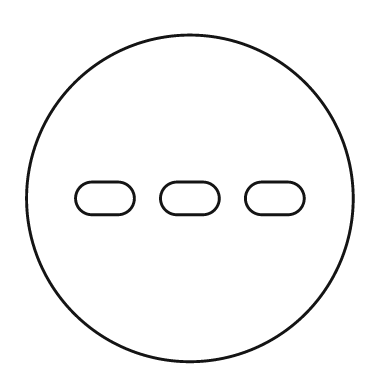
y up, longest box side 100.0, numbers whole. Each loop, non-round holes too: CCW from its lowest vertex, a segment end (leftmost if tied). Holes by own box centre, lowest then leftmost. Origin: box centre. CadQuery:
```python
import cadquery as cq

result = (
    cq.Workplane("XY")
    .moveTo(0.0, 0.0)
    .circle(50.0)
    .moveTo(-30.0, -5.0)
    .lineTo(-22.0, -5.0)
    .threePointArc((-17.0, 0.0), (-22.0, 5.0))
    .lineTo(-30.0, 5.0)
    .threePointArc((-35.0, 0.0), (-30.0, -5.0))
    .close()
    .moveTo(-4.0, -5.0)
    .lineTo(4.0, -5.0)
    .threePointArc((9.0, 0.0), (4.0, 5.0))
    .lineTo(-4.0, 5.0)
    .threePointArc((-9.0, 0.0), (-4.0, -5.0))
    .close()
    .moveTo(22.0, -5.0)
    .lineTo(30.0, -5.0)
    .threePointArc((35.0, 0.0), (30.0, 5.0))
    .lineTo(22.0, 5.0)
    .threePointArc((17.0, 0.0), (22.0, -5.0))
    .close()
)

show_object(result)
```